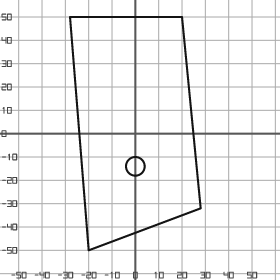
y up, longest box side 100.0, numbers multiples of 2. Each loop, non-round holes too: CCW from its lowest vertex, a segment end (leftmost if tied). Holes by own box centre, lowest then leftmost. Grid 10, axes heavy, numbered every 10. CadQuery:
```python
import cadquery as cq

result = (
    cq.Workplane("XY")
    .moveTo(-20.0, -50.0)
    .lineTo(28.0, -32.0)
    .lineTo(20.0, 50.0)
    .lineTo(-28.0, 50.0)
    .close()
    .moveTo(0.0, -14.0)
    .circle(4.0)
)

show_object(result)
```